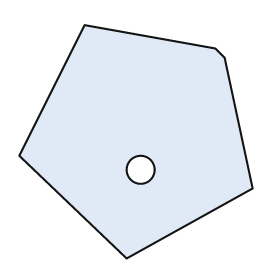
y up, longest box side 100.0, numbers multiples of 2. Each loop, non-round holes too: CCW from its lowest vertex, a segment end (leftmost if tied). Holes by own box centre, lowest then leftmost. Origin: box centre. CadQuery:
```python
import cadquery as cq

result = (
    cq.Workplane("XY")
    .moveTo(-4.0, -50.0)
    .lineTo(50.0, -20.0)
    .lineTo(38.0, 36.0)
    .lineTo(34.0, 40.0)
    .lineTo(-22.0, 50.0)
    .lineTo(-50.0, -6.0)
    .close()
    .moveTo(2.0, -12.0)
    .circle(6.0)
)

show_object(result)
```